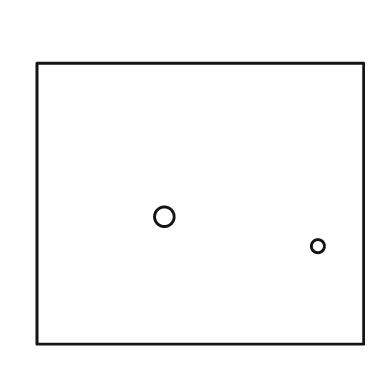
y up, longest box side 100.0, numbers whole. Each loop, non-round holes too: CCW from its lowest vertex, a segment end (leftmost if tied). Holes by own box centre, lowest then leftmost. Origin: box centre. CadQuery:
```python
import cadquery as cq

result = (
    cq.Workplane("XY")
    .moveTo(-50.0, -43.0)
    .lineTo(50.0, -43.0)
    .lineTo(50.0, 43.0)
    .lineTo(-50.0, 43.0)
    .close()
    .moveTo(36.0, -13.0)
    .circle(2.0)
    .moveTo(-11.0, -4.0)
    .circle(3.0)
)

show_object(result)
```